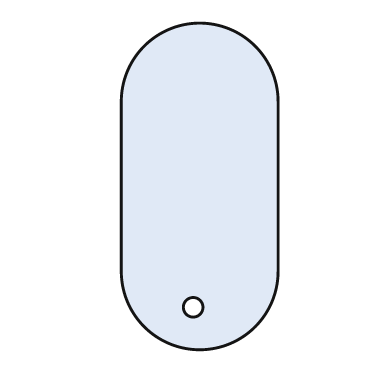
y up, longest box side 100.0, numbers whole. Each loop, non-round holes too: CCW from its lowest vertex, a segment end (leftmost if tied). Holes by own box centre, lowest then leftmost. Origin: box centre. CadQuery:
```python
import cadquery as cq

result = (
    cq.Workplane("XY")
    .moveTo(-24.0, -26.0)
    .threePointArc((0.0, -50.0), (24.0, -26.0))
    .lineTo(24.0, 26.0)
    .threePointArc((0.0, 50.0), (-24.0, 26.0))
    .close()
    .moveTo(-2.0, -37.0)
    .circle(3.0)
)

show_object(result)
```